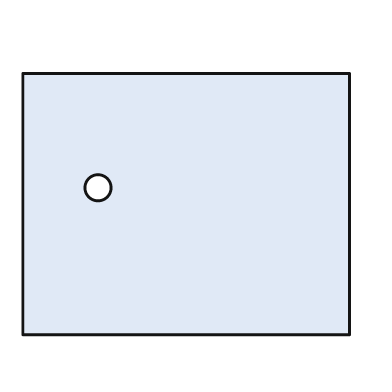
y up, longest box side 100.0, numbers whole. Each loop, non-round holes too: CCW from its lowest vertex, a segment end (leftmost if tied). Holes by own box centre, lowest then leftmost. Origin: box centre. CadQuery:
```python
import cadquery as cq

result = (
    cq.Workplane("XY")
    .moveTo(-50.0, -40.0)
    .lineTo(50.0, -40.0)
    .lineTo(50.0, 40.0)
    .lineTo(-50.0, 40.0)
    .close()
    .moveTo(-27.0, 5.0)
    .circle(4.0)
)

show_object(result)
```